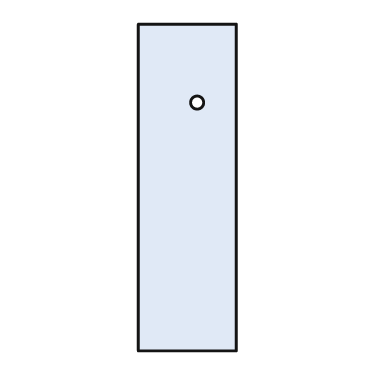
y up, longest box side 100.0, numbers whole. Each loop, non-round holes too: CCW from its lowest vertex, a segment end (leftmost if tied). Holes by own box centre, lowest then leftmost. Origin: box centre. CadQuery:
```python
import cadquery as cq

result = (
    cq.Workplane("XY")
    .moveTo(-15.0, -50.0)
    .lineTo(15.0, -50.0)
    .lineTo(15.0, 50.0)
    .lineTo(-15.0, 50.0)
    .close()
    .moveTo(3.0, 26.0)
    .circle(2.0)
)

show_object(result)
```